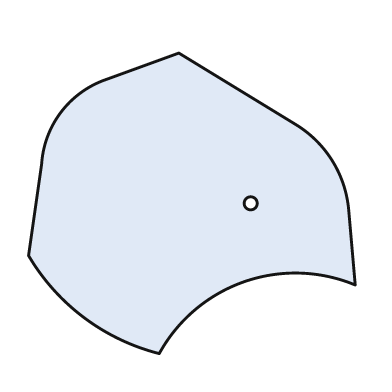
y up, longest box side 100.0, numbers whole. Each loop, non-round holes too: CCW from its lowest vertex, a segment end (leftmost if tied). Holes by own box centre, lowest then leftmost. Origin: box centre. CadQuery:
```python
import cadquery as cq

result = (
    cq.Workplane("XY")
    .moveTo(-10.0, -46.0)
    .threePointArc((16.0, -24.0), (50.0, -25.0))
    .lineTo(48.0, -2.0)
    .threePointArc((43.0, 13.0), (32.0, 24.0))
    .lineTo(-4.0, 46.0)
    .lineTo(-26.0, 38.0)
    .threePointArc((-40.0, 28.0), (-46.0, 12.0))
    .lineTo(-50.0, -16.0)
    .threePointArc((-33.0, -35.0), (-10.0, -46.0))
    .close()
    .moveTo(18.0, 0.0)
    .circle(2.0)
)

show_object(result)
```